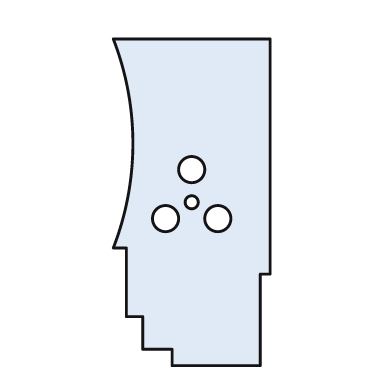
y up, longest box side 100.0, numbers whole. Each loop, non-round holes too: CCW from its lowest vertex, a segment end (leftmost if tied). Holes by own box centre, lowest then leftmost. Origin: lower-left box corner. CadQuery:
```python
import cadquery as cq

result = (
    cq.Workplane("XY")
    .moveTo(18.0, 0.0)
    .lineTo(45.0, 0.0)
    .lineTo(45.0, 28.0)
    .lineTo(48.0, 28.0)
    .lineTo(48.0, 100.0)
    .lineTo(0.0, 100.0)
    .threePointArc((6.0, 68.0), (0.0, 36.0))
    .lineTo(4.0, 36.0)
    .lineTo(4.0, 15.0)
    .lineTo(9.0, 15.0)
    .lineTo(9.0, 5.0)
    .lineTo(18.0, 5.0)
    .close()
    .moveTo(16.0, 45.0)
    .circle(4.0)
    .moveTo(32.0, 45.0)
    .circle(4.0)
    .moveTo(24.0, 50.0)
    .circle(2.0)
    .moveTo(24.0, 60.0)
    .circle(4.0)
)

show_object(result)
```